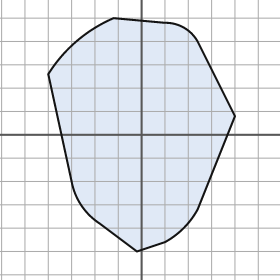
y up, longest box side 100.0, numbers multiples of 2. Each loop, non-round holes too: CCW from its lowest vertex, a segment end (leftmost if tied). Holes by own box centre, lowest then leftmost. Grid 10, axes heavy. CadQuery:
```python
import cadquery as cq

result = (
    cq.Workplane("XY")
    .moveTo(-2.0, -50.0)
    .lineTo(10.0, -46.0)
    .threePointArc((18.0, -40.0), (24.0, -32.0))
    .lineTo(40.0, 8.0)
    .lineTo(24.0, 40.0)
    .threePointArc((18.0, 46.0), (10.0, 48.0))
    .lineTo(-12.0, 50.0)
    .threePointArc((-28.0, 40.0), (-40.0, 26.0))
    .lineTo(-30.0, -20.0)
    .threePointArc((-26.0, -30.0), (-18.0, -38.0))
    .close()
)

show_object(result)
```